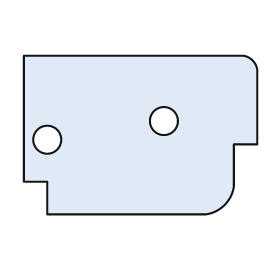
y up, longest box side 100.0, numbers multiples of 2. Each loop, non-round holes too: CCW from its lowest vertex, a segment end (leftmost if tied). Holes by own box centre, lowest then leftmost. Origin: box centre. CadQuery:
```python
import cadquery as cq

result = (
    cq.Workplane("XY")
    .moveTo(-40.0, -34.0)
    .lineTo(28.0, -34.0)
    .threePointArc((36.0, -30.0), (40.0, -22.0))
    .lineTo(40.0, -4.0)
    .lineTo(50.0, -4.0)
    .lineTo(50.0, 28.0)
    .threePointArc((48.0, 32.0), (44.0, 34.0))
    .lineTo(-50.0, 34.0)
    .lineTo(-50.0, -20.0)
    .lineTo(-40.0, -20.0)
    .close()
    .moveTo(-40.0, -2.0)
    .circle(6.0)
    .moveTo(10.0, 6.0)
    .circle(6.0)
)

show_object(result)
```